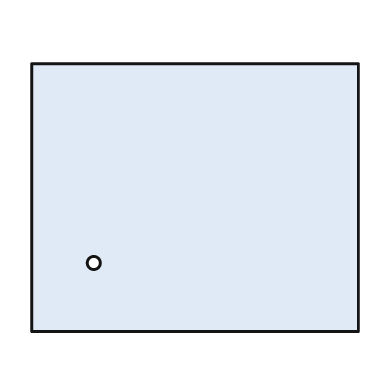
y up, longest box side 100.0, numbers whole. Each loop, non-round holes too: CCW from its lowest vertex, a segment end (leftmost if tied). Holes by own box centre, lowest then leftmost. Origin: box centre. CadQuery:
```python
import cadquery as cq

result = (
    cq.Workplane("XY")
    .moveTo(-50.0, -41.0)
    .lineTo(50.0, -41.0)
    .lineTo(50.0, 41.0)
    .lineTo(-50.0, 41.0)
    .close()
    .moveTo(-31.0, -20.0)
    .circle(2.0)
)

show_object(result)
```